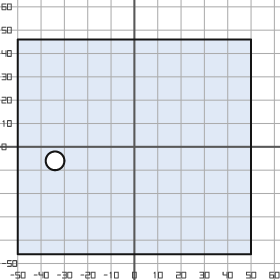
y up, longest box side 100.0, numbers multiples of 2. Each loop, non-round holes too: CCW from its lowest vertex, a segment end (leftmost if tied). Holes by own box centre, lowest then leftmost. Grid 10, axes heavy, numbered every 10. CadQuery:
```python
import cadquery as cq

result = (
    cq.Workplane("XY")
    .moveTo(-50.0, -46.0)
    .lineTo(50.0, -46.0)
    .lineTo(50.0, 46.0)
    .lineTo(-50.0, 46.0)
    .close()
    .moveTo(-34.0, -6.0)
    .circle(4.0)
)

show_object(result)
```